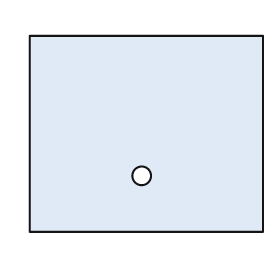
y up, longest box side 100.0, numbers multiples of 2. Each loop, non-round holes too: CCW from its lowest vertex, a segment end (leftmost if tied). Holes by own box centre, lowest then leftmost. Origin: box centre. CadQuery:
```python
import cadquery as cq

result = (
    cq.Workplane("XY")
    .moveTo(-50.0, -42.0)
    .lineTo(50.0, -42.0)
    .lineTo(50.0, 42.0)
    .lineTo(-50.0, 42.0)
    .close()
    .moveTo(-2.0, -18.0)
    .circle(4.0)
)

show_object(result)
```